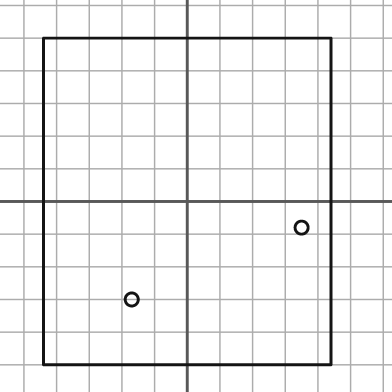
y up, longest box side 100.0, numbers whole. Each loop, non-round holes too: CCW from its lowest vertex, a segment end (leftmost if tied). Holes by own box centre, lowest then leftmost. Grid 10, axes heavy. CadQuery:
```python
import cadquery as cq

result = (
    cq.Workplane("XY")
    .moveTo(-44.0, -50.0)
    .lineTo(44.0, -50.0)
    .lineTo(44.0, 50.0)
    .lineTo(-44.0, 50.0)
    .close()
    .moveTo(-17.0, -30.0)
    .circle(2.0)
    .moveTo(35.0, -8.0)
    .circle(2.0)
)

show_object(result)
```